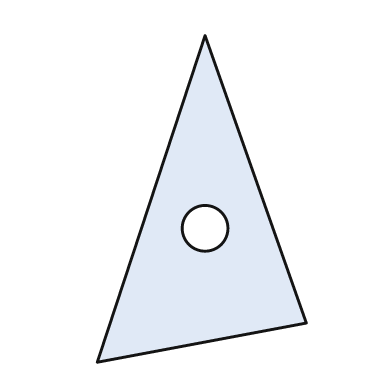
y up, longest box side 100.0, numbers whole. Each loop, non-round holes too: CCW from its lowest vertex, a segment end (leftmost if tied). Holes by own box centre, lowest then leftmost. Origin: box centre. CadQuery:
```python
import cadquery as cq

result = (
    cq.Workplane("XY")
    .moveTo(-32.0, -50.0)
    .lineTo(32.0, -38.0)
    .lineTo(1.0, 50.0)
    .close()
    .moveTo(1.0, -9.0)
    .circle(7.0)
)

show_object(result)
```